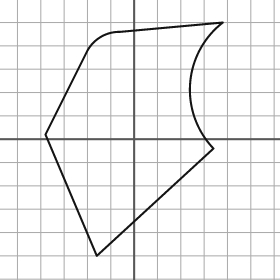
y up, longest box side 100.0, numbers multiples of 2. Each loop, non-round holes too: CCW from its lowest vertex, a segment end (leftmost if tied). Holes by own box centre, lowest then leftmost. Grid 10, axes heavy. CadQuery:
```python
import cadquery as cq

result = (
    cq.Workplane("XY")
    .moveTo(-16.0, -50.0)
    .lineTo(34.0, -4.0)
    .threePointArc((24.0, 24.0), (38.0, 50.0))
    .lineTo(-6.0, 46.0)
    .threePointArc((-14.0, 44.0), (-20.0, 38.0))
    .lineTo(-38.0, 2.0)
    .close()
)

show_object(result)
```